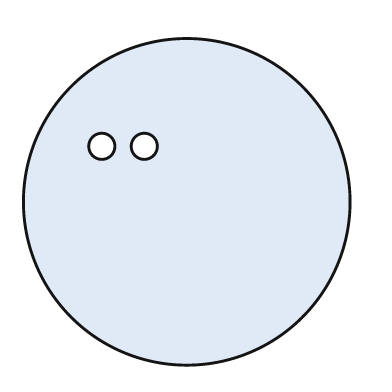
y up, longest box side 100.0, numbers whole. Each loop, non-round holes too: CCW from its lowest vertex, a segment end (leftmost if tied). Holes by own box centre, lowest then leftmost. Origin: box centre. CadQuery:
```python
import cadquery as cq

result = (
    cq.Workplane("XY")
    .moveTo(0.0, 0.0)
    .circle(50.0)
    .moveTo(-26.0, 17.0)
    .circle(4.0)
    .moveTo(-13.0, 17.0)
    .circle(4.0)
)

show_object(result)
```